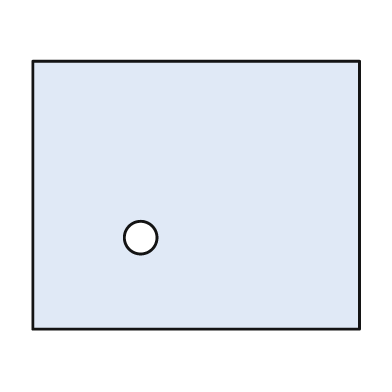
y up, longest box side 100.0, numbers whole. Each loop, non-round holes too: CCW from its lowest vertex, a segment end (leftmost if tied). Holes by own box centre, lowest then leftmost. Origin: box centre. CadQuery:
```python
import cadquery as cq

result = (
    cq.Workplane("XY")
    .moveTo(-50.0, -41.0)
    .lineTo(50.0, -41.0)
    .lineTo(50.0, 41.0)
    .lineTo(-50.0, 41.0)
    .close()
    .moveTo(-17.0, -13.0)
    .circle(5.0)
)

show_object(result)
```